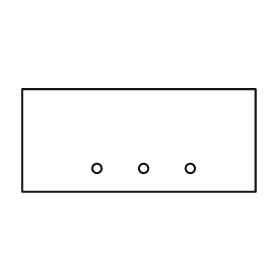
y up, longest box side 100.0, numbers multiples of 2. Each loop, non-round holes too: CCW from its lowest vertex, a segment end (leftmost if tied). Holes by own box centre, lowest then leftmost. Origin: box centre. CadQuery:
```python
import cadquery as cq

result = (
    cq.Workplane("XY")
    .moveTo(-50.0, -22.0)
    .lineTo(50.0, -22.0)
    .lineTo(50.0, 22.0)
    .lineTo(-50.0, 22.0)
    .close()
    .moveTo(-18.0, -12.0)
    .circle(2.0)
    .moveTo(2.0, -12.0)
    .circle(2.0)
    .moveTo(22.0, -12.0)
    .circle(2.0)
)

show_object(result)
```